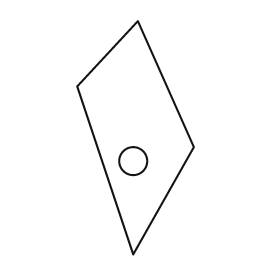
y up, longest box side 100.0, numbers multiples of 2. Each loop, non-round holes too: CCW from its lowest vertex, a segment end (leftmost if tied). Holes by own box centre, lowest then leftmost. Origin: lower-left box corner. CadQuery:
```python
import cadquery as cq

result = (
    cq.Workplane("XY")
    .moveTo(24.0, 0.0)
    .lineTo(50.0, 46.0)
    .lineTo(26.0, 100.0)
    .lineTo(0.0, 72.0)
    .close()
    .moveTo(24.0, 40.0)
    .circle(6.0)
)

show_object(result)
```